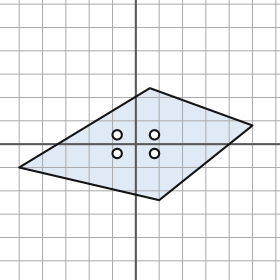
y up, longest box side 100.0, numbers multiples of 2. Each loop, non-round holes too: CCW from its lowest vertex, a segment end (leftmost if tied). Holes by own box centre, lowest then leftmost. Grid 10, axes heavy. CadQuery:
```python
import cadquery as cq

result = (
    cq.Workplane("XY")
    .moveTo(10.0, -24.0)
    .lineTo(50.0, 8.0)
    .lineTo(6.0, 24.0)
    .lineTo(-50.0, -10.0)
    .close()
    .moveTo(-8.0, -4.0)
    .circle(2.0)
    .moveTo(8.0, -4.0)
    .circle(2.0)
    .moveTo(-8.0, 4.0)
    .circle(2.0)
    .moveTo(8.0, 4.0)
    .circle(2.0)
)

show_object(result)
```